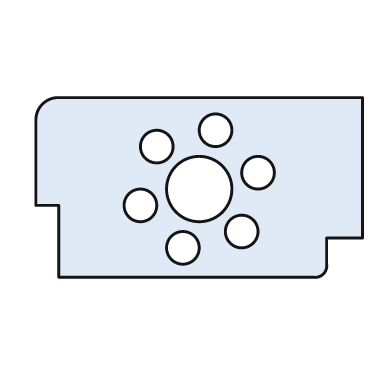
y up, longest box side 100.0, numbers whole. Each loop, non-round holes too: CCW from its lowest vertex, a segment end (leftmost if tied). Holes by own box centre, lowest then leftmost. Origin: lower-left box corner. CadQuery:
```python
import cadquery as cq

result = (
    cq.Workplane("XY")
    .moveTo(7.0, 0.0)
    .lineTo(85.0, 0.0)
    .threePointArc((88.0, 1.0), (89.0, 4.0))
    .lineTo(89.0, 12.0)
    .lineTo(100.0, 12.0)
    .lineTo(100.0, 55.0)
    .lineTo(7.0, 55.0)
    .threePointArc((2.0, 53.0), (0.0, 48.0))
    .lineTo(0.0, 22.0)
    .lineTo(7.0, 22.0)
    .close()
    .moveTo(45.0, 9.0)
    .circle(5.0)
    .moveTo(63.0, 14.0)
    .circle(5.0)
    .moveTo(32.0, 22.0)
    .circle(5.0)
    .moveTo(50.0, 27.0)
    .circle(10.0)
    .moveTo(68.0, 32.0)
    .circle(5.0)
    .moveTo(37.0, 40.0)
    .circle(5.0)
    .moveTo(55.0, 45.0)
    .circle(5.0)
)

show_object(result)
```